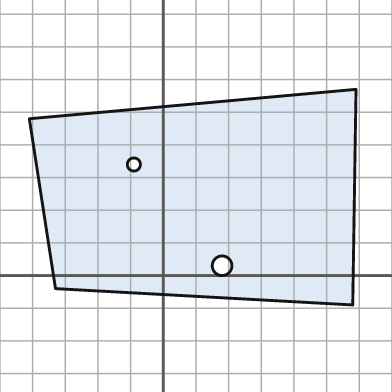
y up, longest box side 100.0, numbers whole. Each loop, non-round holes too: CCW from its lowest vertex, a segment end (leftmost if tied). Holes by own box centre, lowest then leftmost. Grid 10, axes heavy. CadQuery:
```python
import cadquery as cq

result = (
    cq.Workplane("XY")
    .moveTo(58.0, -9.0)
    .lineTo(59.0, 57.0)
    .lineTo(-41.0, 48.0)
    .lineTo(-33.0, -4.0)
    .close()
    .moveTo(18.0, 3.0)
    .circle(3.0)
    .moveTo(-9.0, 34.0)
    .circle(2.0)
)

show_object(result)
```